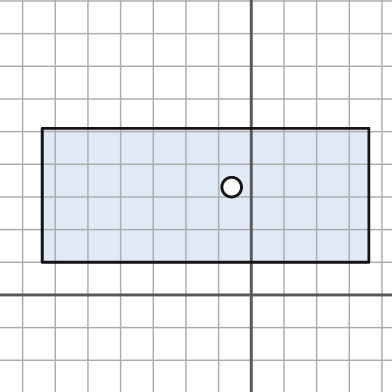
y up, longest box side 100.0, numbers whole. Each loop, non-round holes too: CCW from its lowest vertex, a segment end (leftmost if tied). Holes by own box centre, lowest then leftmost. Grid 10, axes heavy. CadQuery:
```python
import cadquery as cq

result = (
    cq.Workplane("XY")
    .moveTo(-64.0, 10.0)
    .lineTo(36.0, 10.0)
    .lineTo(36.0, 51.0)
    .lineTo(-64.0, 51.0)
    .close()
    .moveTo(-6.0, 33.0)
    .circle(3.0)
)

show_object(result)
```